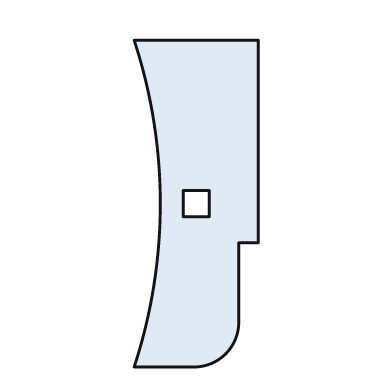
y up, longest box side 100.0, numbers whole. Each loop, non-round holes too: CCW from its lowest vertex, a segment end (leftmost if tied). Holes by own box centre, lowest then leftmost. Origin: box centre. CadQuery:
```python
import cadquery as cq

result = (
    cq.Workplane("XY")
    .moveTo(-19.0, -50.0)
    .lineTo(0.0, -50.0)
    .threePointArc((9.0, -46.0), (13.0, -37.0))
    .lineTo(13.0, -12.0)
    .lineTo(19.0, -12.0)
    .lineTo(19.0, 50.0)
    .lineTo(-19.0, 50.0)
    .threePointArc((-11.0, 0.0), (-19.0, -50.0))
    .close()
    .moveTo(-4.0, -4.0)
    .lineTo(4.0, -4.0)
    .lineTo(4.0, 4.0)
    .lineTo(-4.0, 4.0)
    .close()
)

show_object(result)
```